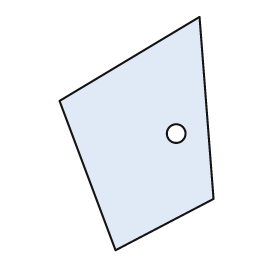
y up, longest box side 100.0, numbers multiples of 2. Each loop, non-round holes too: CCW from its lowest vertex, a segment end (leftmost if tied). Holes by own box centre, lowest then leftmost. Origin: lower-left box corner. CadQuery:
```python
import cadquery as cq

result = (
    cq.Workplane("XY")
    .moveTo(24.0, 0.0)
    .lineTo(66.0, 22.0)
    .lineTo(60.0, 100.0)
    .lineTo(0.0, 64.0)
    .close()
    .moveTo(50.0, 50.0)
    .circle(4.0)
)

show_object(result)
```